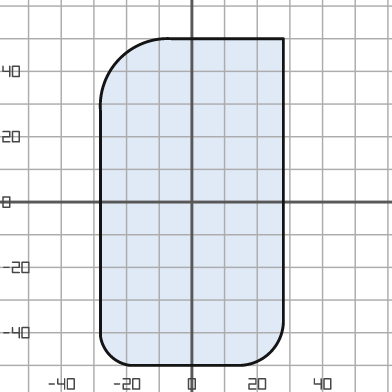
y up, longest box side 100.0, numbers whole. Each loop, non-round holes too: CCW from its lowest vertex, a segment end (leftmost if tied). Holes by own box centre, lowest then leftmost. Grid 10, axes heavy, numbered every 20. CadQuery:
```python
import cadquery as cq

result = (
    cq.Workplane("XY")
    .moveTo(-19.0, -50.0)
    .lineTo(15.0, -50.0)
    .threePointArc((24.0, -46.0), (28.0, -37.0))
    .lineTo(28.0, 50.0)
    .lineTo(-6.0, 50.0)
    .threePointArc((-22.0, 44.0), (-28.0, 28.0))
    .lineTo(-28.0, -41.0)
    .threePointArc((-25.0, -47.0), (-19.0, -50.0))
    .close()
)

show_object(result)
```